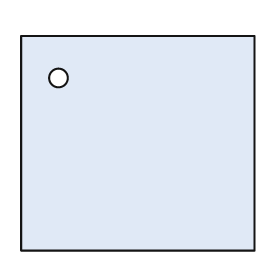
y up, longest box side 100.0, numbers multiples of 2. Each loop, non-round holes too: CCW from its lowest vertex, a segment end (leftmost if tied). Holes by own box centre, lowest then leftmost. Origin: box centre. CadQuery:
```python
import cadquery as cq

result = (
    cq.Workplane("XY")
    .moveTo(-50.0, -46.0)
    .lineTo(50.0, -46.0)
    .lineTo(50.0, 46.0)
    .lineTo(-50.0, 46.0)
    .close()
    .moveTo(-34.0, 28.0)
    .circle(4.0)
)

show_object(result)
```